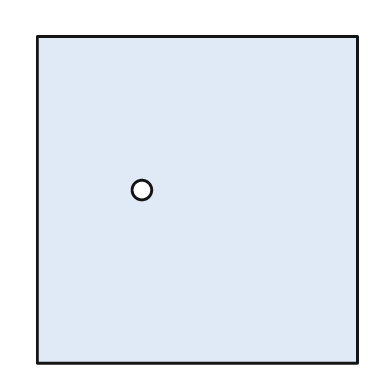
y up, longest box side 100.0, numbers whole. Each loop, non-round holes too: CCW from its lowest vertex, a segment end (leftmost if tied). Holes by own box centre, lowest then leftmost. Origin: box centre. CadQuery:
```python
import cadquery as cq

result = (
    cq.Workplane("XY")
    .moveTo(-49.0, -50.0)
    .lineTo(49.0, -50.0)
    .lineTo(49.0, 50.0)
    .lineTo(-49.0, 50.0)
    .close()
    .moveTo(-17.0, 3.0)
    .circle(3.0)
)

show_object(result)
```